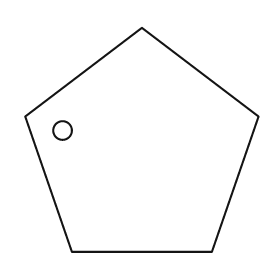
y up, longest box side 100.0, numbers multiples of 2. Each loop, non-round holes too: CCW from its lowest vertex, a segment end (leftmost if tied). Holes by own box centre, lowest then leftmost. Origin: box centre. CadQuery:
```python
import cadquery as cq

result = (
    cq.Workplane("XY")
    .moveTo(-30.0, -48.0)
    .lineTo(30.0, -48.0)
    .lineTo(50.0, 10.0)
    .lineTo(0.0, 48.0)
    .lineTo(-50.0, 10.0)
    .close()
    .moveTo(-34.0, 4.0)
    .circle(4.0)
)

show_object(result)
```